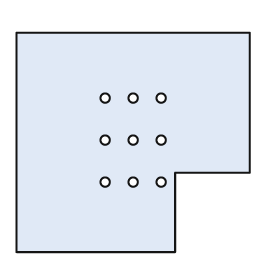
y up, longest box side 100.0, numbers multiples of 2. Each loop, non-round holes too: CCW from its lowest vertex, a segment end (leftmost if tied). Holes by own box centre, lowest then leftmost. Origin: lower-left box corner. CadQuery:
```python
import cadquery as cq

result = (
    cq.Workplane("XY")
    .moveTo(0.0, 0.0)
    .lineTo(68.0, 0.0)
    .lineTo(68.0, 34.0)
    .lineTo(100.0, 34.0)
    .lineTo(100.0, 94.0)
    .lineTo(0.0, 94.0)
    .close()
    .moveTo(38.0, 30.0)
    .circle(2.0)
    .moveTo(50.0, 30.0)
    .circle(2.0)
    .moveTo(62.0, 30.0)
    .circle(2.0)
    .moveTo(38.0, 48.0)
    .circle(2.0)
    .moveTo(50.0, 48.0)
    .circle(2.0)
    .moveTo(62.0, 48.0)
    .circle(2.0)
    .moveTo(38.0, 66.0)
    .circle(2.0)
    .moveTo(50.0, 66.0)
    .circle(2.0)
    .moveTo(62.0, 66.0)
    .circle(2.0)
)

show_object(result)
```